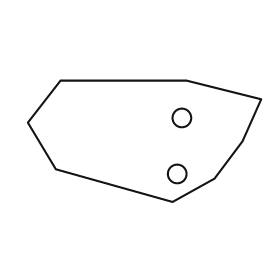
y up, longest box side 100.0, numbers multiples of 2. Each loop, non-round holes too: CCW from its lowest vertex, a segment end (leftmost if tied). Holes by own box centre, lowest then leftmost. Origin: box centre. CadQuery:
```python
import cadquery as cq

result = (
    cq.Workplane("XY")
    .moveTo(12.0, -26.0)
    .lineTo(30.0, -16.0)
    .lineTo(42.0, 0.0)
    .lineTo(50.0, 18.0)
    .lineTo(18.0, 26.0)
    .lineTo(-36.0, 26.0)
    .lineTo(-50.0, 8.0)
    .lineTo(-38.0, -12.0)
    .close()
    .moveTo(14.0, -14.0)
    .circle(4.0)
    .moveTo(16.0, 10.0)
    .circle(4.0)
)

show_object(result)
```